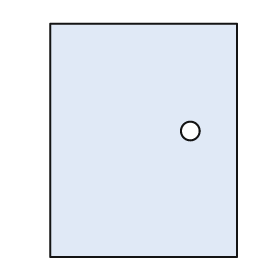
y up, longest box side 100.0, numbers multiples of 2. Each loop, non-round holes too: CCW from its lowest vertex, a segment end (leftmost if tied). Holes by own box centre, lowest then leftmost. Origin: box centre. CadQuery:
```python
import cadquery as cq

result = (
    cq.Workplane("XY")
    .moveTo(-40.0, -50.0)
    .lineTo(40.0, -50.0)
    .lineTo(40.0, 50.0)
    .lineTo(-40.0, 50.0)
    .close()
    .moveTo(20.0, 4.0)
    .circle(4.0)
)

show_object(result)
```